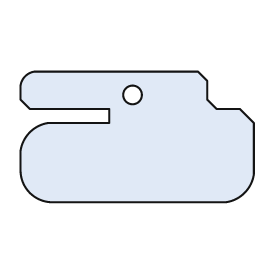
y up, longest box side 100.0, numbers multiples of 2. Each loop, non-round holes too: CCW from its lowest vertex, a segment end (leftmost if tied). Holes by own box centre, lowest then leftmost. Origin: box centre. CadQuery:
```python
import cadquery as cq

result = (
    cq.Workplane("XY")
    .moveTo(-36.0, -28.0)
    .lineTo(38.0, -28.0)
    .threePointArc((46.0, -24.0), (50.0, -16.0))
    .lineTo(50.0, 6.0)
    .lineTo(44.0, 12.0)
    .lineTo(34.0, 12.0)
    .lineTo(30.0, 16.0)
    .lineTo(30.0, 24.0)
    .lineTo(26.0, 28.0)
    .lineTo(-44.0, 28.0)
    .threePointArc((-48.0, 26.0), (-50.0, 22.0))
    .lineTo(-50.0, 16.0)
    .lineTo(-46.0, 12.0)
    .lineTo(-12.0, 12.0)
    .lineTo(-12.0, 6.0)
    .lineTo(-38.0, 6.0)
    .threePointArc((-46.0, 2.0), (-50.0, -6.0))
    .lineTo(-50.0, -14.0)
    .threePointArc((-46.0, -24.0), (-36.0, -28.0))
    .close()
    .moveTo(-2.0, 18.0)
    .circle(4.0)
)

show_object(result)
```